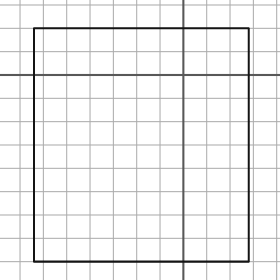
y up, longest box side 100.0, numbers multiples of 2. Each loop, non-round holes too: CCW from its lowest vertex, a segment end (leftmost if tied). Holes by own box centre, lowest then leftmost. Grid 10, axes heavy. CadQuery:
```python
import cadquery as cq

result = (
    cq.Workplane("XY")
    .moveTo(-64.0, -80.0)
    .lineTo(28.0, -80.0)
    .lineTo(28.0, 20.0)
    .lineTo(-64.0, 20.0)
    .close()
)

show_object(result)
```